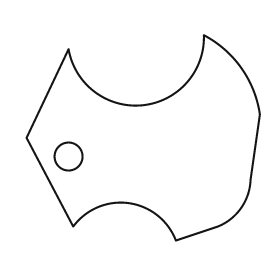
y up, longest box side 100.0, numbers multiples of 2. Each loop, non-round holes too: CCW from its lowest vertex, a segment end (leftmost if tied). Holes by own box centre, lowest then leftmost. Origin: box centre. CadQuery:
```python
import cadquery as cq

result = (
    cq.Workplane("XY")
    .moveTo(14.0, -44.0)
    .lineTo(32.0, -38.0)
    .threePointArc((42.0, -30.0), (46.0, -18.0))
    .lineTo(50.0, 10.0)
    .threePointArc((42.0, 30.0), (26.0, 44.0))
    .threePointArc((0.0, 14.0), (-32.0, 38.0))
    .lineTo(-50.0, 0.0)
    .lineTo(-30.0, -38.0)
    .threePointArc((-6.0, -28.0), (14.0, -44.0))
    .close()
    .moveTo(-32.0, -8.0)
    .circle(6.0)
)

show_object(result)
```